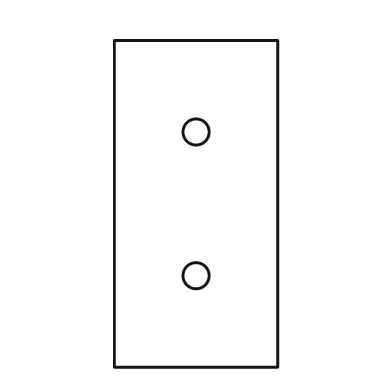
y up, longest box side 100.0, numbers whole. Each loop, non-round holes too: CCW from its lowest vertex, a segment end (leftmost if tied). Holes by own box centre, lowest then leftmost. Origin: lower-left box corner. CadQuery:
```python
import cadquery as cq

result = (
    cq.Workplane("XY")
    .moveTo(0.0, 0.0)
    .lineTo(50.0, 0.0)
    .lineTo(50.0, 100.0)
    .lineTo(0.0, 100.0)
    .close()
    .moveTo(25.0, 28.0)
    .circle(4.0)
    .moveTo(25.0, 72.0)
    .circle(4.0)
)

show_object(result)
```